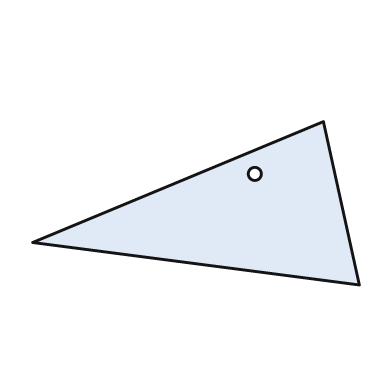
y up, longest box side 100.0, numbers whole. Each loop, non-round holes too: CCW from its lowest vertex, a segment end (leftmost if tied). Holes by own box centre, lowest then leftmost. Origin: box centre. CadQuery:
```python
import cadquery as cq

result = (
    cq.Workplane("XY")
    .moveTo(50.0, -25.0)
    .lineTo(39.0, 25.0)
    .lineTo(-50.0, -12.0)
    .close()
    .moveTo(18.0, 9.0)
    .circle(2.0)
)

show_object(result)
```